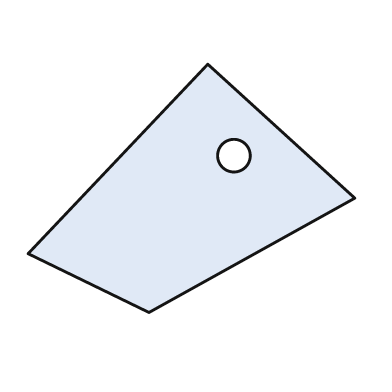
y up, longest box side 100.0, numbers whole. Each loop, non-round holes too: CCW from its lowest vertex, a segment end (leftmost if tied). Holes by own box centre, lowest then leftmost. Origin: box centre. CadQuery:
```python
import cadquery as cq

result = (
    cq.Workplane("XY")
    .moveTo(-13.0, -38.0)
    .lineTo(50.0, -3.0)
    .lineTo(5.0, 38.0)
    .lineTo(-50.0, -20.0)
    .close()
    .moveTo(13.0, 10.0)
    .circle(5.0)
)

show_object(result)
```